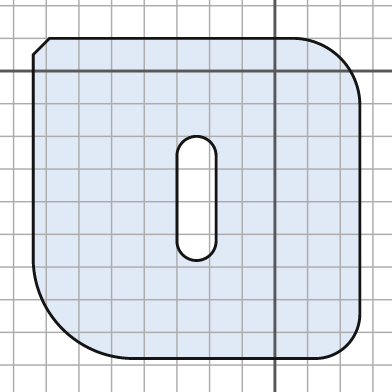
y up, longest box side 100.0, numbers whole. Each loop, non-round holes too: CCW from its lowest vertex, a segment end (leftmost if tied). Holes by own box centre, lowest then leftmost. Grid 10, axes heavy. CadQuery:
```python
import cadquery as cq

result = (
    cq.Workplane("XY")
    .moveTo(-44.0, -88.0)
    .lineTo(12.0, -88.0)
    .threePointArc((22.0, -84.0), (26.0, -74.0))
    .lineTo(26.0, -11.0)
    .threePointArc((20.0, 4.0), (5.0, 10.0))
    .lineTo(-69.0, 10.0)
    .lineTo(-74.0, 5.0)
    .lineTo(-74.0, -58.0)
    .threePointArc((-65.0, -79.0), (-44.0, -88.0))
    .close()
    .moveTo(-30.0, -52.0)
    .threePointArc((-24.0, -58.0), (-18.0, -52.0))
    .lineTo(-18.0, -26.0)
    .threePointArc((-24.0, -20.0), (-30.0, -26.0))
    .close()
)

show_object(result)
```